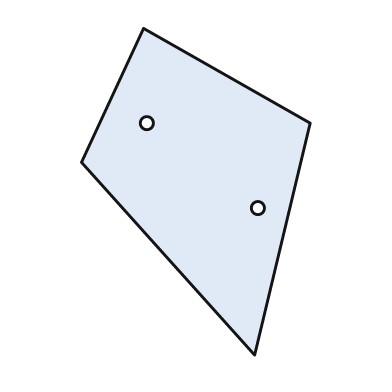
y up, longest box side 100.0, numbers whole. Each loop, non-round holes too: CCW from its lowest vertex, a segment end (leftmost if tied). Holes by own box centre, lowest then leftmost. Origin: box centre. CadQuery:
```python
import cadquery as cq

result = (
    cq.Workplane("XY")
    .moveTo(18.0, -50.0)
    .lineTo(35.0, 21.0)
    .lineTo(-16.0, 50.0)
    .lineTo(-35.0, 9.0)
    .close()
    .moveTo(19.0, -5.0)
    .circle(2.0)
    .moveTo(-15.0, 21.0)
    .circle(2.0)
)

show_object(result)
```